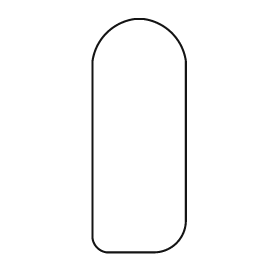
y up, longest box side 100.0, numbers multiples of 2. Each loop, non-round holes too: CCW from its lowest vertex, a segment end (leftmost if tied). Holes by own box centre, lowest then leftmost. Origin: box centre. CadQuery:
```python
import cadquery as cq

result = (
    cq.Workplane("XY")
    .moveTo(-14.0, -50.0)
    .lineTo(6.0, -50.0)
    .threePointArc((16.0, -46.0), (20.0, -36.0))
    .lineTo(20.0, 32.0)
    .threePointArc((14.0, 44.0), (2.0, 50.0))
    .lineTo(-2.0, 50.0)
    .threePointArc((-14.0, 44.0), (-20.0, 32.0))
    .lineTo(-20.0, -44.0)
    .threePointArc((-18.0, -48.0), (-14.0, -50.0))
    .close()
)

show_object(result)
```